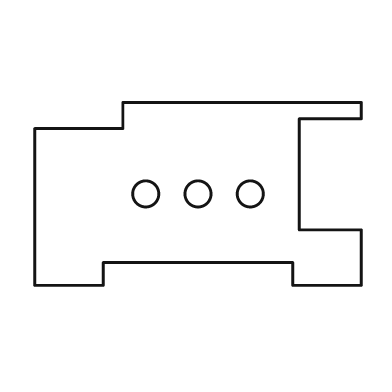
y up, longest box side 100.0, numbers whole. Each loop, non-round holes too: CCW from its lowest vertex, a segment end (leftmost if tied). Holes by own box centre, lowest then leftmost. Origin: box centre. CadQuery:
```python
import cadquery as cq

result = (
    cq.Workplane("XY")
    .moveTo(-50.0, -28.0)
    .lineTo(-29.0, -28.0)
    .lineTo(-29.0, -21.0)
    .lineTo(29.0, -21.0)
    .lineTo(29.0, -28.0)
    .lineTo(50.0, -28.0)
    .lineTo(50.0, -11.0)
    .lineTo(31.0, -11.0)
    .lineTo(31.0, 23.0)
    .lineTo(50.0, 23.0)
    .lineTo(50.0, 28.0)
    .lineTo(-23.0, 28.0)
    .lineTo(-23.0, 20.0)
    .lineTo(-50.0, 20.0)
    .close()
    .moveTo(-16.0, 0.0)
    .circle(4.0)
    .moveTo(0.0, 0.0)
    .circle(4.0)
    .moveTo(16.0, 0.0)
    .circle(4.0)
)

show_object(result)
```